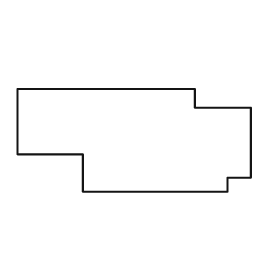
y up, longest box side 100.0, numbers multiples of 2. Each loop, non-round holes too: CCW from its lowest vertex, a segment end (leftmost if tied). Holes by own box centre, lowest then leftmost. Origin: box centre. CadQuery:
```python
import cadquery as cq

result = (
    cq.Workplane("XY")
    .moveTo(-22.0, -22.0)
    .lineTo(40.0, -22.0)
    .lineTo(40.0, -16.0)
    .lineTo(50.0, -16.0)
    .lineTo(50.0, 14.0)
    .lineTo(26.0, 14.0)
    .lineTo(26.0, 22.0)
    .lineTo(-50.0, 22.0)
    .lineTo(-50.0, -6.0)
    .lineTo(-22.0, -6.0)
    .close()
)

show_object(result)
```